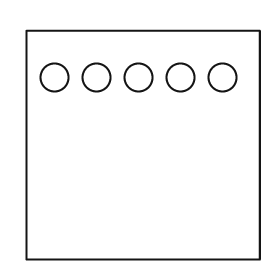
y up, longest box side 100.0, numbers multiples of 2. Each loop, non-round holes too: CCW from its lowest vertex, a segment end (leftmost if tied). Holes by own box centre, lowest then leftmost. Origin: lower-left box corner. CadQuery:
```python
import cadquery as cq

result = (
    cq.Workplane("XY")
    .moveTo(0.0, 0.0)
    .lineTo(100.0, 0.0)
    .lineTo(100.0, 98.0)
    .lineTo(0.0, 98.0)
    .close()
    .moveTo(12.0, 78.0)
    .circle(6.0)
    .moveTo(30.0, 78.0)
    .circle(6.0)
    .moveTo(48.0, 78.0)
    .circle(6.0)
    .moveTo(66.0, 78.0)
    .circle(6.0)
    .moveTo(84.0, 78.0)
    .circle(6.0)
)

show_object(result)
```